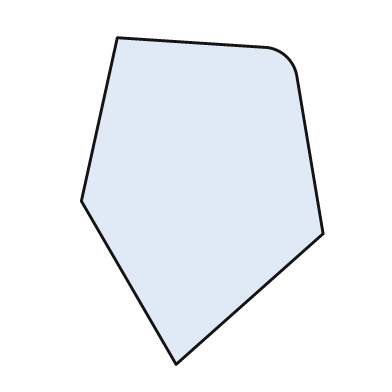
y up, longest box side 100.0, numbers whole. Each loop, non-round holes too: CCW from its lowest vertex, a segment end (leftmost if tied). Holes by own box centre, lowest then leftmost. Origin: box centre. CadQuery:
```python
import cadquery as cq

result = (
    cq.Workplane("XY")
    .moveTo(-8.0, -50.0)
    .lineTo(37.0, -10.0)
    .lineTo(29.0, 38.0)
    .threePointArc((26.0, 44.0), (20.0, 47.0))
    .lineTo(-26.0, 50.0)
    .lineTo(-37.0, 0.0)
    .close()
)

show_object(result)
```